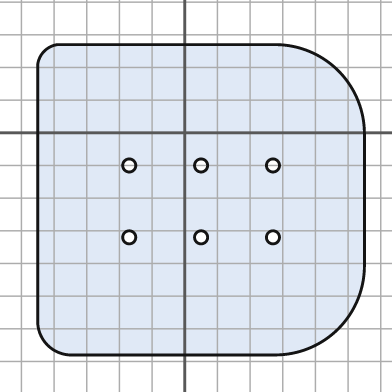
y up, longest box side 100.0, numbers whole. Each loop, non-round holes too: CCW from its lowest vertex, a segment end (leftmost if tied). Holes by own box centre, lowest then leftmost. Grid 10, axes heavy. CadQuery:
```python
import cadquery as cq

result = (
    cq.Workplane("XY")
    .moveTo(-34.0, -68.0)
    .lineTo(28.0, -68.0)
    .threePointArc((47.0, -60.0), (55.0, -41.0))
    .lineTo(55.0, 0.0)
    .threePointArc((47.0, 19.0), (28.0, 27.0))
    .lineTo(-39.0, 27.0)
    .threePointArc((-43.0, 25.0), (-45.0, 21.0))
    .lineTo(-45.0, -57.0)
    .threePointArc((-42.0, -65.0), (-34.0, -68.0))
    .close()
    .moveTo(-17.0, -32.0)
    .circle(2.0)
    .moveTo(5.0, -32.0)
    .circle(2.0)
    .moveTo(27.0, -32.0)
    .circle(2.0)
    .moveTo(-17.0, -10.0)
    .circle(2.0)
    .moveTo(5.0, -10.0)
    .circle(2.0)
    .moveTo(27.0, -10.0)
    .circle(2.0)
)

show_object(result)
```